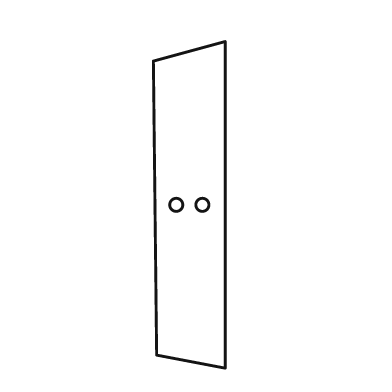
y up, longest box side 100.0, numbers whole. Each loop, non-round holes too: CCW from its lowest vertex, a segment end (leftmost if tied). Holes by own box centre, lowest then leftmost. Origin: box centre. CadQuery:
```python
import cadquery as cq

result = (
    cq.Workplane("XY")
    .moveTo(11.0, -50.0)
    .lineTo(11.0, 50.0)
    .lineTo(-11.0, 44.0)
    .lineTo(-10.0, -46.0)
    .close()
    .moveTo(-4.0, 0.0)
    .circle(2.0)
    .moveTo(4.0, 0.0)
    .circle(2.0)
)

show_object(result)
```